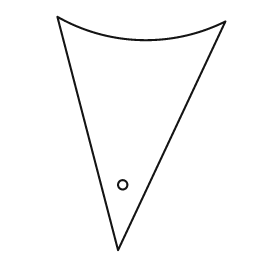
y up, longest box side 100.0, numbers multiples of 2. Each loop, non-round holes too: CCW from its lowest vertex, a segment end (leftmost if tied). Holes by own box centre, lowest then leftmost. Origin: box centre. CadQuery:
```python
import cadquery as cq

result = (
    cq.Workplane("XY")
    .moveTo(-10.0, -50.0)
    .lineTo(36.0, 48.0)
    .threePointArc((0.0, 40.0), (-36.0, 50.0))
    .close()
    .moveTo(-8.0, -22.0)
    .circle(2.0)
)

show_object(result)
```